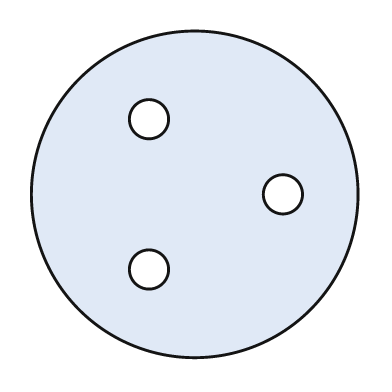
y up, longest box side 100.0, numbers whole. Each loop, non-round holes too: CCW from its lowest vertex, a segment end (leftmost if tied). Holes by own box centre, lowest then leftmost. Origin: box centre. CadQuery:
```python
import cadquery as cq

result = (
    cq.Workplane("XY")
    .moveTo(0.0, 0.0)
    .circle(50.0)
    .moveTo(-14.0, -23.0)
    .circle(6.0)
    .moveTo(27.0, 0.0)
    .circle(6.0)
    .moveTo(-14.0, 23.0)
    .circle(6.0)
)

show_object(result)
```